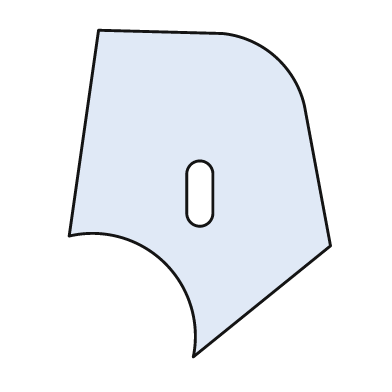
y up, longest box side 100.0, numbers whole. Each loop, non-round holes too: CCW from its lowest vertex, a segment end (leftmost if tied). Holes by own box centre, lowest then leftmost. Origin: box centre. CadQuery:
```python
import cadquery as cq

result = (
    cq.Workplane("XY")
    .moveTo(-2.0, -50.0)
    .lineTo(40.0, -16.0)
    .lineTo(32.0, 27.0)
    .threePointArc((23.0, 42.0), (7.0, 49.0))
    .lineTo(-31.0, 50.0)
    .lineTo(-40.0, -13.0)
    .threePointArc((-11.0, -21.0), (-2.0, -50.0))
    .close()
    .moveTo(-4.0, -6.0)
    .threePointArc((0.0, -10.0), (4.0, -6.0))
    .lineTo(4.0, 6.0)
    .threePointArc((0.0, 10.0), (-4.0, 6.0))
    .close()
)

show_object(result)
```